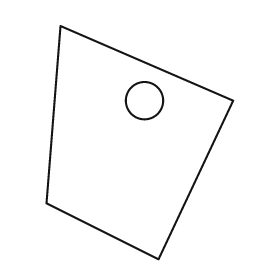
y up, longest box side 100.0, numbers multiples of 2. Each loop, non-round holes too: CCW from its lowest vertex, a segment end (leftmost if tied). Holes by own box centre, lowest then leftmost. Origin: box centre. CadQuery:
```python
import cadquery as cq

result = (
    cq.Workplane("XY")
    .moveTo(8.0, -50.0)
    .lineTo(40.0, 18.0)
    .lineTo(-34.0, 50.0)
    .lineTo(-40.0, -26.0)
    .close()
    .moveTo(2.0, 18.0)
    .circle(8.0)
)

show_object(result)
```